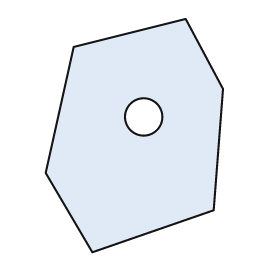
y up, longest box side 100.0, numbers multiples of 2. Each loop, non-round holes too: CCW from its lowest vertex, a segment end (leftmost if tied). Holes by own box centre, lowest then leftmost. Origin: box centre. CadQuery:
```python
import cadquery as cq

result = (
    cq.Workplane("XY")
    .moveTo(-18.0, -50.0)
    .lineTo(34.0, -32.0)
    .lineTo(38.0, 20.0)
    .lineTo(22.0, 50.0)
    .lineTo(-26.0, 38.0)
    .lineTo(-38.0, -16.0)
    .close()
    .moveTo(4.0, 8.0)
    .circle(8.0)
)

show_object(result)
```